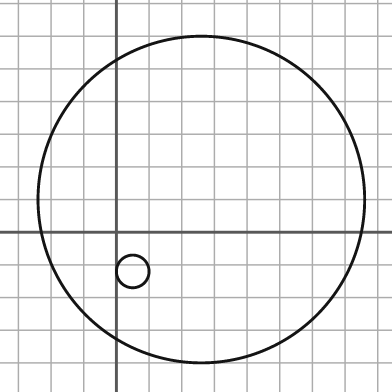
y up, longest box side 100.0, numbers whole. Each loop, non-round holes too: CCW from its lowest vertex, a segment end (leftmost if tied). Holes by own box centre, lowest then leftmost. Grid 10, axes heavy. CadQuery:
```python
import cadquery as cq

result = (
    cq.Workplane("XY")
    .moveTo(26.0, 10.0)
    .circle(50.0)
    .moveTo(5.0, -12.0)
    .circle(5.0)
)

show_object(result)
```